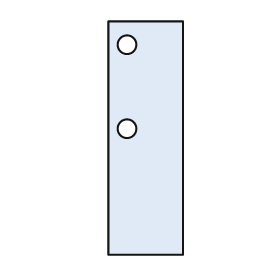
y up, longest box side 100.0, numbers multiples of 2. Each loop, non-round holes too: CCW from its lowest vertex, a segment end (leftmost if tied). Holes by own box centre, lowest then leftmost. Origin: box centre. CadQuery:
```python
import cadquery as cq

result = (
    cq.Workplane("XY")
    .moveTo(-16.0, -50.0)
    .lineTo(16.0, -50.0)
    .lineTo(16.0, 50.0)
    .lineTo(-16.0, 50.0)
    .close()
    .moveTo(-8.0, 4.0)
    .circle(4.0)
    .moveTo(-8.0, 40.0)
    .circle(4.0)
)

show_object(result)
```